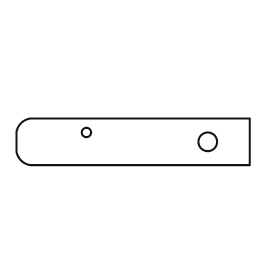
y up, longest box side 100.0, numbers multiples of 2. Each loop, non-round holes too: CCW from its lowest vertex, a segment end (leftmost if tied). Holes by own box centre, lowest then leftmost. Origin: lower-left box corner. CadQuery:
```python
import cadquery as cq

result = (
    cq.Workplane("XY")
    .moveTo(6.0, 0.0)
    .lineTo(100.0, 0.0)
    .lineTo(100.0, 20.0)
    .lineTo(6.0, 20.0)
    .threePointArc((2.0, 18.0), (0.0, 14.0))
    .lineTo(0.0, 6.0)
    .threePointArc((2.0, 2.0), (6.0, 0.0))
    .close()
    .moveTo(82.0, 10.0)
    .circle(4.0)
    .moveTo(30.0, 14.0)
    .circle(2.0)
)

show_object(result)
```